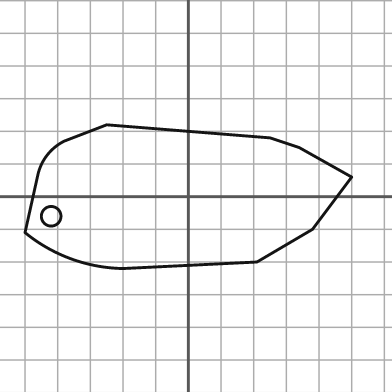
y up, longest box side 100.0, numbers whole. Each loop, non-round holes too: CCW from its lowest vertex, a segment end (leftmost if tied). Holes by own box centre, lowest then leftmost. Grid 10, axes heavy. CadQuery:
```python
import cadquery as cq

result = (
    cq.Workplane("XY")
    .moveTo(-20.0, -22.0)
    .lineTo(21.0, -20.0)
    .lineTo(38.0, -10.0)
    .lineTo(50.0, 6.0)
    .lineTo(34.0, 15.0)
    .lineTo(25.0, 18.0)
    .lineTo(-25.0, 22.0)
    .lineTo(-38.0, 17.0)
    .threePointArc((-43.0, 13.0), (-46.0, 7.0))
    .lineTo(-50.0, -11.0)
    .threePointArc((-36.0, -19.0), (-20.0, -22.0))
    .close()
    .moveTo(-42.0, -6.0)
    .circle(3.0)
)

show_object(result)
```